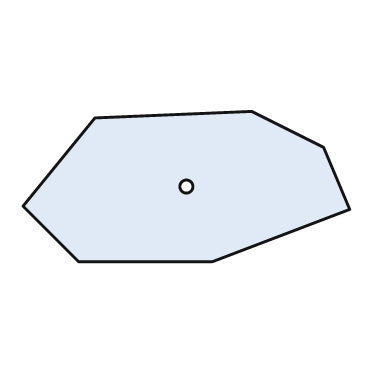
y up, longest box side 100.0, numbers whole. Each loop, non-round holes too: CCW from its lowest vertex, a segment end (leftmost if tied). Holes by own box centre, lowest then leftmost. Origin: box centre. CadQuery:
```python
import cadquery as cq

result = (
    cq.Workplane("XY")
    .moveTo(-33.0, -23.0)
    .lineTo(8.0, -23.0)
    .lineTo(50.0, -7.0)
    .lineTo(42.0, 12.0)
    .lineTo(20.0, 23.0)
    .lineTo(-28.0, 21.0)
    .lineTo(-50.0, -6.0)
    .close()
    .moveTo(0.0, 0.0)
    .circle(2.0)
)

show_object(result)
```